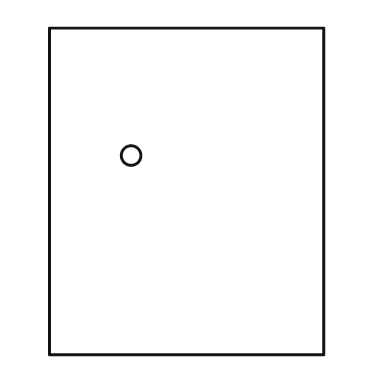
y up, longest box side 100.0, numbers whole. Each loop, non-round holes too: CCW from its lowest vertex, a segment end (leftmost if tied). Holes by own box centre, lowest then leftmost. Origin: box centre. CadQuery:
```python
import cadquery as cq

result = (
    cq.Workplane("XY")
    .moveTo(-42.0, -50.0)
    .lineTo(42.0, -50.0)
    .lineTo(42.0, 50.0)
    .lineTo(-42.0, 50.0)
    .close()
    .moveTo(-17.0, 11.0)
    .circle(3.0)
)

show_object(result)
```